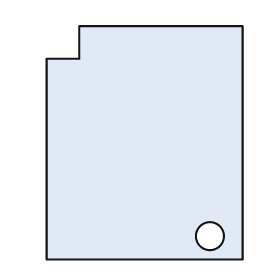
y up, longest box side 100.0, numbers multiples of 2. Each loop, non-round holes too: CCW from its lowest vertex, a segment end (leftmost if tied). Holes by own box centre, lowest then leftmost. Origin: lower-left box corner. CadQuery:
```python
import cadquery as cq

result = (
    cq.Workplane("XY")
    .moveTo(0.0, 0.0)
    .lineTo(84.0, 0.0)
    .lineTo(84.0, 100.0)
    .lineTo(14.0, 100.0)
    .lineTo(14.0, 86.0)
    .lineTo(0.0, 86.0)
    .close()
    .moveTo(70.0, 10.0)
    .circle(6.0)
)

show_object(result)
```